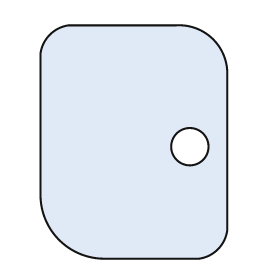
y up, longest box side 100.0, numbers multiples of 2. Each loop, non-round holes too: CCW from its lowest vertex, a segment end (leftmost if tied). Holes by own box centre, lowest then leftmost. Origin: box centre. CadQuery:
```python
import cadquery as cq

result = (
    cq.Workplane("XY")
    .moveTo(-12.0, -50.0)
    .lineTo(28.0, -50.0)
    .threePointArc((36.0, -46.0), (40.0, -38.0))
    .lineTo(40.0, 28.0)
    .threePointArc((34.0, 44.0), (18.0, 50.0))
    .lineTo(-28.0, 50.0)
    .threePointArc((-36.0, 46.0), (-40.0, 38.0))
    .lineTo(-40.0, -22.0)
    .threePointArc((-32.0, -42.0), (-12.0, -50.0))
    .close()
    .moveTo(24.0, -2.0)
    .circle(8.0)
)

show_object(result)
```